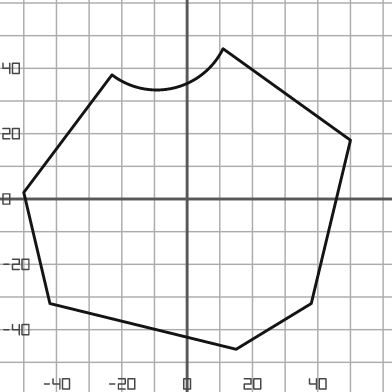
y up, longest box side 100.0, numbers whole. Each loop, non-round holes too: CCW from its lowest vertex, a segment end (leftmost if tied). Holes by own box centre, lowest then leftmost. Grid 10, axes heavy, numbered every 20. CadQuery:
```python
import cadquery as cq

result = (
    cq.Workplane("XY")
    .moveTo(15.0, -46.0)
    .lineTo(38.0, -32.0)
    .lineTo(50.0, 18.0)
    .lineTo(11.0, 46.0)
    .threePointArc((-4.0, 34.0), (-23.0, 38.0))
    .lineTo(-50.0, 2.0)
    .lineTo(-42.0, -32.0)
    .close()
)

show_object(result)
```